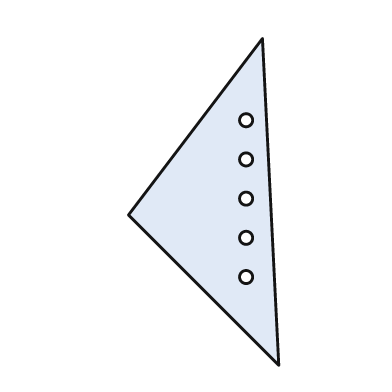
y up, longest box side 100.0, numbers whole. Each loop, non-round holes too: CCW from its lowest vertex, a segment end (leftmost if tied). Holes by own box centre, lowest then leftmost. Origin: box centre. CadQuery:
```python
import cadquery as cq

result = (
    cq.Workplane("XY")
    .moveTo(23.0, -50.0)
    .lineTo(18.0, 50.0)
    .lineTo(-23.0, -4.0)
    .close()
    .moveTo(13.0, -23.0)
    .circle(2.0)
    .moveTo(13.0, -11.0)
    .circle(2.0)
    .moveTo(13.0, 1.0)
    .circle(2.0)
    .moveTo(13.0, 13.0)
    .circle(2.0)
    .moveTo(13.0, 25.0)
    .circle(2.0)
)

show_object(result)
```